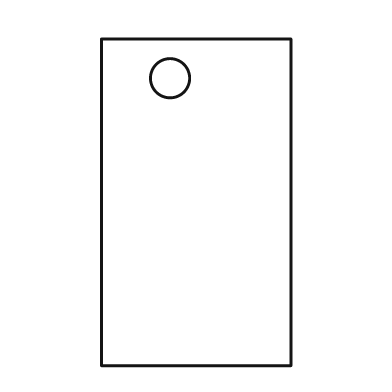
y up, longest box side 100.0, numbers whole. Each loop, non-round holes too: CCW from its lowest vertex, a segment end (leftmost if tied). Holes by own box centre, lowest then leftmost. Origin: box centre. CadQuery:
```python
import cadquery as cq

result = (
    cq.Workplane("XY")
    .moveTo(-29.0, -50.0)
    .lineTo(29.0, -50.0)
    .lineTo(29.0, 50.0)
    .lineTo(-29.0, 50.0)
    .close()
    .moveTo(-8.0, 38.0)
    .circle(6.0)
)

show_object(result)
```